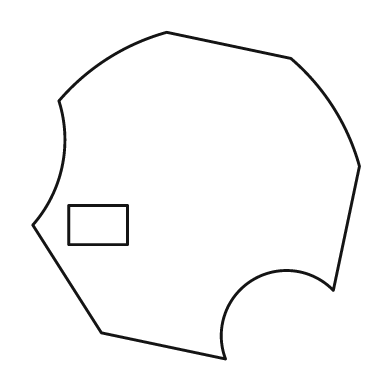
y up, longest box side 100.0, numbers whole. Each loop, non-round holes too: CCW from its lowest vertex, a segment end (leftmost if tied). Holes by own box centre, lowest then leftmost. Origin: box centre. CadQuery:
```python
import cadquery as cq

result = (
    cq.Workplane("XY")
    .moveTo(9.0, -50.0)
    .threePointArc((17.0, -26.0), (42.0, -29.0))
    .lineTo(50.0, 9.0)
    .threePointArc((42.0, 27.0), (29.0, 42.0))
    .lineTo(-9.0, 50.0)
    .threePointArc((-27.0, 42.0), (-42.0, 29.0))
    .threePointArc((-41.0, 9.0), (-50.0, -9.0))
    .lineTo(-29.0, -42.0)
    .close()
    .moveTo(-39.0, -15.0)
    .lineTo(-21.0, -15.0)
    .lineTo(-21.0, -3.0)
    .lineTo(-39.0, -3.0)
    .close()
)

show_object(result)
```